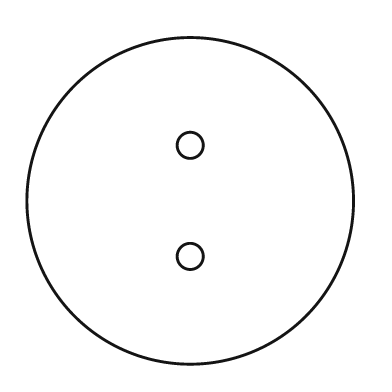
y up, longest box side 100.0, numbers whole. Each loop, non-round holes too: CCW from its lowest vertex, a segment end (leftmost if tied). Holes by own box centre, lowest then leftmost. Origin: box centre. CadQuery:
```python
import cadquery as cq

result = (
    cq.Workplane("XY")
    .moveTo(0.0, 0.0)
    .circle(50.0)
    .moveTo(0.0, -17.0)
    .circle(4.0)
    .moveTo(0.0, 17.0)
    .circle(4.0)
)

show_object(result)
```